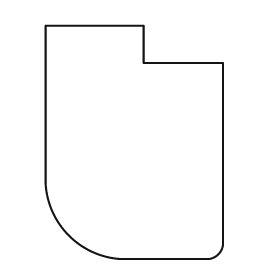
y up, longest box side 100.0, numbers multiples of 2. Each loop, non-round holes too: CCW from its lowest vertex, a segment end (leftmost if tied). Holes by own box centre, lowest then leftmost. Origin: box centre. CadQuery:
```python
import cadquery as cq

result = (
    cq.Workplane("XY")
    .moveTo(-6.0, -50.0)
    .lineTo(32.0, -50.0)
    .threePointArc((36.0, -48.0), (38.0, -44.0))
    .lineTo(38.0, 34.0)
    .lineTo(4.0, 34.0)
    .lineTo(4.0, 50.0)
    .lineTo(-38.0, 50.0)
    .lineTo(-38.0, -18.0)
    .threePointArc((-28.0, -40.0), (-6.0, -50.0))
    .close()
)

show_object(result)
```